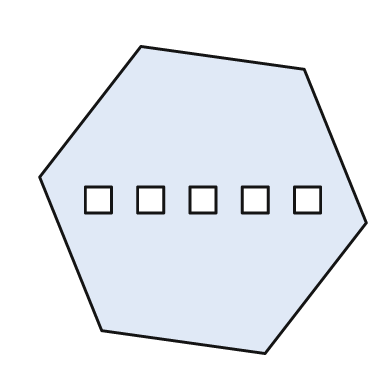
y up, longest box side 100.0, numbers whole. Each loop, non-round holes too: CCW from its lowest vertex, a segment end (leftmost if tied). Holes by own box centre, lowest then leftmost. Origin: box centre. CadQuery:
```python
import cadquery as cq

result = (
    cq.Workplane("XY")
    .moveTo(19.0, -47.0)
    .lineTo(50.0, -7.0)
    .lineTo(31.0, 40.0)
    .lineTo(-19.0, 47.0)
    .lineTo(-50.0, 7.0)
    .lineTo(-31.0, -40.0)
    .close()
    .moveTo(-36.0, -4.0)
    .lineTo(-28.0, -4.0)
    .lineTo(-28.0, 4.0)
    .lineTo(-36.0, 4.0)
    .close()
    .moveTo(-20.0, -4.0)
    .lineTo(-12.0, -4.0)
    .lineTo(-12.0, 4.0)
    .lineTo(-20.0, 4.0)
    .close()
    .moveTo(-4.0, -4.0)
    .lineTo(4.0, -4.0)
    .lineTo(4.0, 4.0)
    .lineTo(-4.0, 4.0)
    .close()
    .moveTo(12.0, -4.0)
    .lineTo(20.0, -4.0)
    .lineTo(20.0, 4.0)
    .lineTo(12.0, 4.0)
    .close()
    .moveTo(28.0, -4.0)
    .lineTo(36.0, -4.0)
    .lineTo(36.0, 4.0)
    .lineTo(28.0, 4.0)
    .close()
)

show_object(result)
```